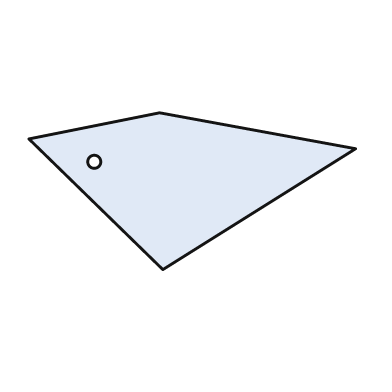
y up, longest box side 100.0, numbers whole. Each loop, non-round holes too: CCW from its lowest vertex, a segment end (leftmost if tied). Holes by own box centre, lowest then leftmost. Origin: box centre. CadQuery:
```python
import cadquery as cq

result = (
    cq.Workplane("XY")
    .moveTo(-9.0, -24.0)
    .lineTo(50.0, 13.0)
    .lineTo(-10.0, 24.0)
    .lineTo(-50.0, 16.0)
    .close()
    .moveTo(-30.0, 9.0)
    .circle(2.0)
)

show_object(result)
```